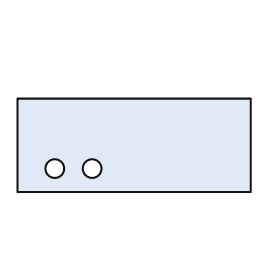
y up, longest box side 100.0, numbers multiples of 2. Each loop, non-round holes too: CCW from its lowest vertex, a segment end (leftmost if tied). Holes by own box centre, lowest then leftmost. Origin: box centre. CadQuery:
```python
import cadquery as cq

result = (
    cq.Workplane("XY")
    .moveTo(-50.0, -20.0)
    .lineTo(50.0, -20.0)
    .lineTo(50.0, 20.0)
    .lineTo(-50.0, 20.0)
    .close()
    .moveTo(-34.0, -10.0)
    .circle(4.0)
    .moveTo(-18.0, -10.0)
    .circle(4.0)
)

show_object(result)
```